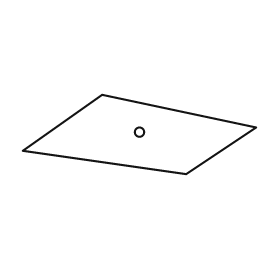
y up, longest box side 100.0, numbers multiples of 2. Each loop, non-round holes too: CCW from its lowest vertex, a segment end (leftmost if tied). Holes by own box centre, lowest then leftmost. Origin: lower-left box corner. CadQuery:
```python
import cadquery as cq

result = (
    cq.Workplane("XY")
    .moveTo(70.0, 0.0)
    .lineTo(100.0, 20.0)
    .lineTo(34.0, 34.0)
    .lineTo(0.0, 10.0)
    .close()
    .moveTo(50.0, 18.0)
    .circle(2.0)
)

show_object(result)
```